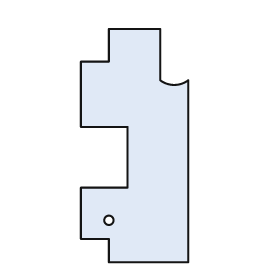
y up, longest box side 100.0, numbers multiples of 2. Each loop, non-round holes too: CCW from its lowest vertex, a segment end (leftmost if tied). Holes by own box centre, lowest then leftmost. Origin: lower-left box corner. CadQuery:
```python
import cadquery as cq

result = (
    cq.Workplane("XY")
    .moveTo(12.0, 0.0)
    .lineTo(46.0, 0.0)
    .lineTo(46.0, 78.0)
    .threePointArc((40.0, 76.0), (34.0, 78.0))
    .lineTo(34.0, 100.0)
    .lineTo(12.0, 100.0)
    .lineTo(12.0, 86.0)
    .lineTo(0.0, 86.0)
    .lineTo(0.0, 58.0)
    .lineTo(20.0, 58.0)
    .lineTo(20.0, 32.0)
    .lineTo(0.0, 32.0)
    .lineTo(0.0, 10.0)
    .lineTo(12.0, 10.0)
    .close()
    .moveTo(12.0, 18.0)
    .circle(2.0)
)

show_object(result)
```